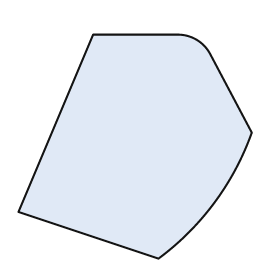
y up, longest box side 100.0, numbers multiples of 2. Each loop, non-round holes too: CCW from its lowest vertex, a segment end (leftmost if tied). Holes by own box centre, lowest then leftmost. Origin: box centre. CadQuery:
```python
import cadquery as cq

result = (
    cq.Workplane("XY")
    .moveTo(10.0, -48.0)
    .threePointArc((34.0, -24.0), (50.0, 6.0))
    .lineTo(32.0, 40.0)
    .threePointArc((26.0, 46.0), (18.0, 48.0))
    .lineTo(-18.0, 48.0)
    .lineTo(-50.0, -28.0)
    .close()
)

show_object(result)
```